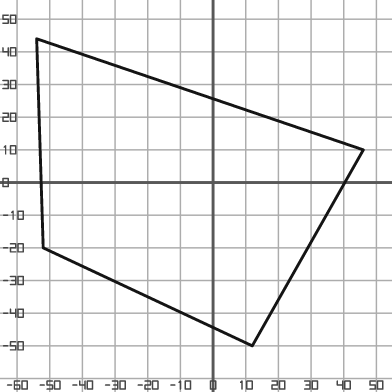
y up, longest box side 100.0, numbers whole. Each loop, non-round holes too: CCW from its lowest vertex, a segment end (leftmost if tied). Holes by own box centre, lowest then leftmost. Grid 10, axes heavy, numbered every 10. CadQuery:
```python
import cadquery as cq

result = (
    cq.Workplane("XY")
    .moveTo(12.0, -50.0)
    .lineTo(46.0, 10.0)
    .lineTo(-54.0, 44.0)
    .lineTo(-52.0, -20.0)
    .close()
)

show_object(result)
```